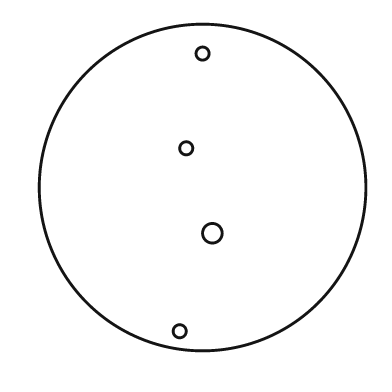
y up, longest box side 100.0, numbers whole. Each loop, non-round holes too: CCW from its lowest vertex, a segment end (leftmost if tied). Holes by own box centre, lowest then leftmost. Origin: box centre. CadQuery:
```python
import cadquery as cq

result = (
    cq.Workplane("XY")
    .moveTo(0.0, 0.0)
    .circle(50.0)
    .moveTo(-7.0, -44.0)
    .circle(2.0)
    .moveTo(3.0, -14.0)
    .circle(3.0)
    .moveTo(-5.0, 12.0)
    .circle(2.0)
    .moveTo(0.0, 41.0)
    .circle(2.0)
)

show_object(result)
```